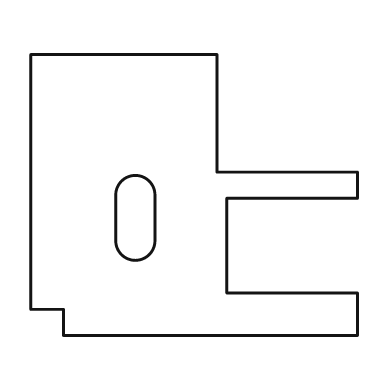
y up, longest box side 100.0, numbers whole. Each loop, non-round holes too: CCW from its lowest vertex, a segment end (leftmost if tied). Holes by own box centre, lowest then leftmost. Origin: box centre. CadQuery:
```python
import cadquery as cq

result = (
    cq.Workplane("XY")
    .moveTo(-40.0, -43.0)
    .lineTo(50.0, -43.0)
    .lineTo(50.0, -30.0)
    .lineTo(10.0, -30.0)
    .lineTo(10.0, -1.0)
    .lineTo(50.0, -1.0)
    .lineTo(50.0, 7.0)
    .lineTo(7.0, 7.0)
    .lineTo(7.0, 43.0)
    .lineTo(-50.0, 43.0)
    .lineTo(-50.0, -35.0)
    .lineTo(-40.0, -35.0)
    .close()
    .moveTo(-24.0, -14.0)
    .threePointArc((-18.0, -20.0), (-12.0, -14.0))
    .lineTo(-12.0, 0.0)
    .threePointArc((-18.0, 6.0), (-24.0, 0.0))
    .close()
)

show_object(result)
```